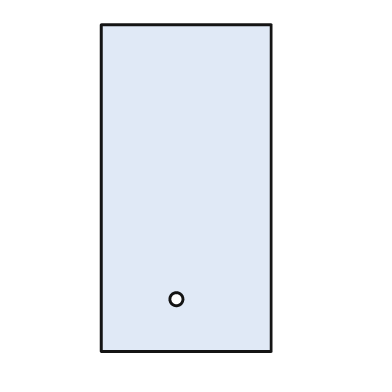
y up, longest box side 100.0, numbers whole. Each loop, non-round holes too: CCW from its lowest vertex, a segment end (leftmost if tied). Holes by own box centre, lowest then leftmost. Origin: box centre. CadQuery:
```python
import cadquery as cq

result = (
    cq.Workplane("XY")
    .moveTo(-26.0, -50.0)
    .lineTo(26.0, -50.0)
    .lineTo(26.0, 50.0)
    .lineTo(-26.0, 50.0)
    .close()
    .moveTo(-3.0, -34.0)
    .circle(2.0)
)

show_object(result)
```